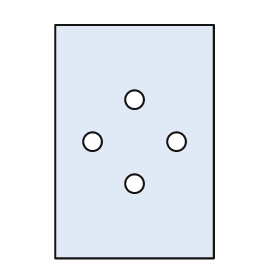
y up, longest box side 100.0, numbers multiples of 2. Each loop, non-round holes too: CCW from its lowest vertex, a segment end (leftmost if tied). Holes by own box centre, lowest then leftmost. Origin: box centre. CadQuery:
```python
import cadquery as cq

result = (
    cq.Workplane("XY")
    .moveTo(-34.0, -50.0)
    .lineTo(34.0, -50.0)
    .lineTo(34.0, 50.0)
    .lineTo(-34.0, 50.0)
    .close()
    .moveTo(0.0, -18.0)
    .circle(4.0)
    .moveTo(-18.0, 0.0)
    .circle(4.0)
    .moveTo(18.0, 0.0)
    .circle(4.0)
    .moveTo(0.0, 18.0)
    .circle(4.0)
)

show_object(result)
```